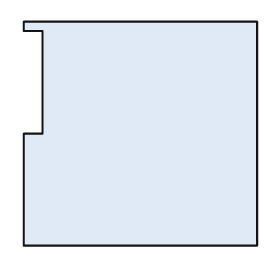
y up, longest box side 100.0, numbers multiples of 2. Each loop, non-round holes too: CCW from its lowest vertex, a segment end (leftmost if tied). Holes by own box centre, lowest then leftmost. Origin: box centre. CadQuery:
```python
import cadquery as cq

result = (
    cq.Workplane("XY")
    .moveTo(-50.0, -48.0)
    .lineTo(50.0, -48.0)
    .lineTo(50.0, 48.0)
    .lineTo(-50.0, 48.0)
    .lineTo(-50.0, 44.0)
    .lineTo(-42.0, 44.0)
    .lineTo(-42.0, 0.0)
    .lineTo(-50.0, 0.0)
    .close()
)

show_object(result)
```